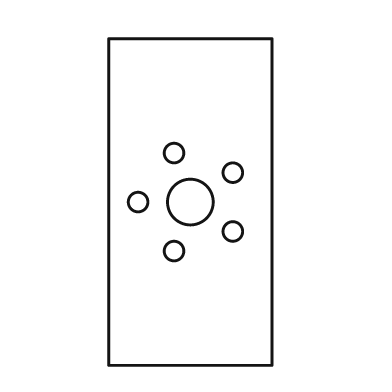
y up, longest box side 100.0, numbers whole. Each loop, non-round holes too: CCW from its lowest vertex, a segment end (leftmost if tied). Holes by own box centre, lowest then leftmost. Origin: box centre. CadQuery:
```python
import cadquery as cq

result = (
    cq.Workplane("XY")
    .moveTo(-25.0, -50.0)
    .lineTo(25.0, -50.0)
    .lineTo(25.0, 50.0)
    .lineTo(-25.0, 50.0)
    .close()
    .moveTo(-5.0, -15.0)
    .circle(3.0)
    .moveTo(13.0, -9.0)
    .circle(3.0)
    .moveTo(-16.0, 0.0)
    .circle(3.0)
    .moveTo(0.0, 0.0)
    .circle(7.0)
    .moveTo(13.0, 9.0)
    .circle(3.0)
    .moveTo(-5.0, 15.0)
    .circle(3.0)
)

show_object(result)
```